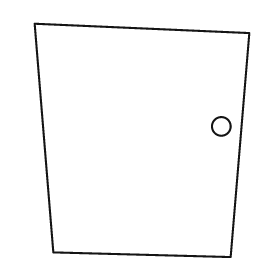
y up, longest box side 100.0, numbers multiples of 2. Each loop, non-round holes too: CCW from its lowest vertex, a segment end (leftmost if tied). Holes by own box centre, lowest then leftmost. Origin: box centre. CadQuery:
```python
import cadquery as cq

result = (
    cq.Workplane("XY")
    .moveTo(38.0, -50.0)
    .lineTo(46.0, 46.0)
    .lineTo(-46.0, 50.0)
    .lineTo(-38.0, -48.0)
    .close()
    .moveTo(34.0, 6.0)
    .circle(4.0)
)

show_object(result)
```